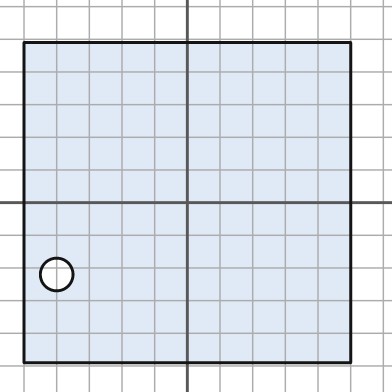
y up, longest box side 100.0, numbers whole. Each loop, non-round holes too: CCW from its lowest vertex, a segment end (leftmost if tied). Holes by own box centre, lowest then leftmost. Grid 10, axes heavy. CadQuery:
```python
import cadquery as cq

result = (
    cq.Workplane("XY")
    .moveTo(-50.0, -49.0)
    .lineTo(50.0, -49.0)
    .lineTo(50.0, 49.0)
    .lineTo(-50.0, 49.0)
    .close()
    .moveTo(-40.0, -22.0)
    .circle(5.0)
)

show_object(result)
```